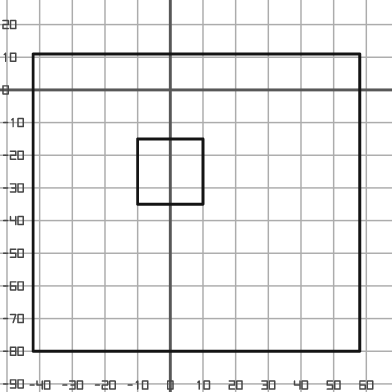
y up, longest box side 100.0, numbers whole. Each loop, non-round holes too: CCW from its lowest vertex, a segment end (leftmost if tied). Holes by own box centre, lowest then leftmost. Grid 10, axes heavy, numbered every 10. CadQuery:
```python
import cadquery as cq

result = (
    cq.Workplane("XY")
    .moveTo(-42.0, -80.0)
    .lineTo(58.0, -80.0)
    .lineTo(58.0, 11.0)
    .lineTo(-42.0, 11.0)
    .close()
    .moveTo(-10.0, -35.0)
    .lineTo(10.0, -35.0)
    .lineTo(10.0, -15.0)
    .lineTo(-10.0, -15.0)
    .close()
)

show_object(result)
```